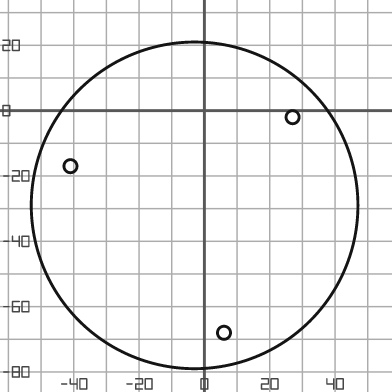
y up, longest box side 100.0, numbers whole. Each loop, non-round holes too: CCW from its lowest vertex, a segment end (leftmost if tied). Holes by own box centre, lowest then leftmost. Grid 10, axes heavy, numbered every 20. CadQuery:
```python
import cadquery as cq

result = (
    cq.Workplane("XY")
    .moveTo(-3.0, -29.0)
    .circle(50.0)
    .moveTo(6.0, -68.0)
    .circle(2.0)
    .moveTo(-41.0, -17.0)
    .circle(2.0)
    .moveTo(27.0, -2.0)
    .circle(2.0)
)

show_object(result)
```